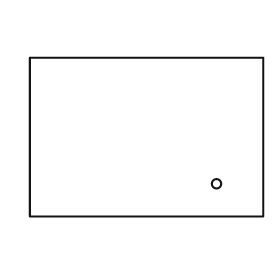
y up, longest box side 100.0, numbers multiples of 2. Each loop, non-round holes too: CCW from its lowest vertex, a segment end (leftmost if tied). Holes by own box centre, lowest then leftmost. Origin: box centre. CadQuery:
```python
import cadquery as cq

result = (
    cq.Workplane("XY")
    .moveTo(-50.0, -34.0)
    .lineTo(50.0, -34.0)
    .lineTo(50.0, 34.0)
    .lineTo(-50.0, 34.0)
    .close()
    .moveTo(30.0, -20.0)
    .circle(2.0)
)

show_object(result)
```